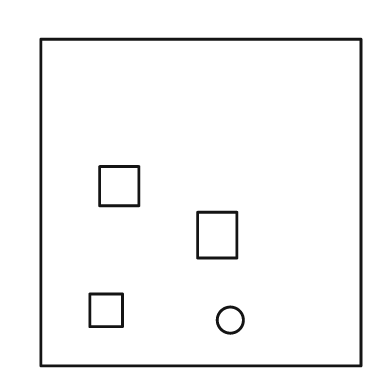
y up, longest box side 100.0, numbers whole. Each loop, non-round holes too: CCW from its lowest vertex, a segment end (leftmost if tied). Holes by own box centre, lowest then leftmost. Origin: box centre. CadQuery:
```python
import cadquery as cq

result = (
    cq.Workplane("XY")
    .moveTo(-49.0, -50.0)
    .lineTo(49.0, -50.0)
    .lineTo(49.0, 50.0)
    .lineTo(-49.0, 50.0)
    .close()
    .moveTo(9.0, -36.0)
    .circle(4.0)
    .moveTo(-34.0, -38.0)
    .lineTo(-24.0, -38.0)
    .lineTo(-24.0, -28.0)
    .lineTo(-34.0, -28.0)
    .close()
    .moveTo(-1.0, -17.0)
    .lineTo(11.0, -17.0)
    .lineTo(11.0, -3.0)
    .lineTo(-1.0, -3.0)
    .close()
    .moveTo(-31.0, -1.0)
    .lineTo(-19.0, -1.0)
    .lineTo(-19.0, 11.0)
    .lineTo(-31.0, 11.0)
    .close()
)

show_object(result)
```